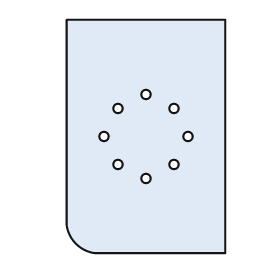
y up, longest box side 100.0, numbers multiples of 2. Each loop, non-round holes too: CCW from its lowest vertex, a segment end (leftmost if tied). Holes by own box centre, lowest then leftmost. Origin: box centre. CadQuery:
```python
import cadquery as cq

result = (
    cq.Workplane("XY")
    .moveTo(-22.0, -50.0)
    .lineTo(34.0, -50.0)
    .lineTo(34.0, 50.0)
    .lineTo(-34.0, 50.0)
    .lineTo(-34.0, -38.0)
    .threePointArc((-30.0, -46.0), (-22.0, -50.0))
    .close()
    .moveTo(0.0, -18.0)
    .circle(2.0)
    .moveTo(-12.0, -12.0)
    .circle(2.0)
    .moveTo(12.0, -12.0)
    .circle(2.0)
    .moveTo(-18.0, 0.0)
    .circle(2.0)
    .moveTo(18.0, 0.0)
    .circle(2.0)
    .moveTo(-12.0, 12.0)
    .circle(2.0)
    .moveTo(12.0, 12.0)
    .circle(2.0)
    .moveTo(0.0, 18.0)
    .circle(2.0)
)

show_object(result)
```